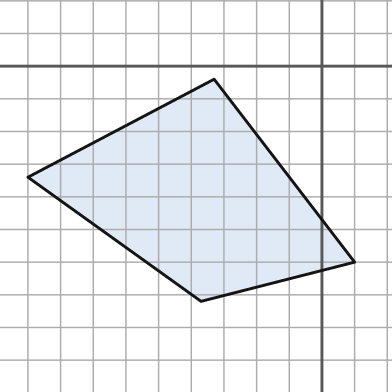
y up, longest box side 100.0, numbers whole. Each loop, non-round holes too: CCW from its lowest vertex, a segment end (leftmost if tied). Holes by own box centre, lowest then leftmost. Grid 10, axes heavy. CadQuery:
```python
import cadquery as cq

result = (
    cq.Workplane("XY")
    .moveTo(-37.0, -72.0)
    .lineTo(10.0, -60.0)
    .lineTo(-33.0, -4.0)
    .lineTo(-90.0, -34.0)
    .close()
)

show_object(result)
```